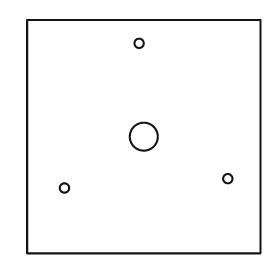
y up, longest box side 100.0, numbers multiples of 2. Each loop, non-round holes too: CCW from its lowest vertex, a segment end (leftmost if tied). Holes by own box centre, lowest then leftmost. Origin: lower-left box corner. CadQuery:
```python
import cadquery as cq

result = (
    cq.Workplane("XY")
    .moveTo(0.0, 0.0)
    .lineTo(100.0, 0.0)
    .lineTo(100.0, 100.0)
    .lineTo(0.0, 100.0)
    .close()
    .moveTo(16.0, 28.0)
    .circle(2.0)
    .moveTo(86.0, 32.0)
    .circle(2.0)
    .moveTo(50.0, 50.0)
    .circle(6.0)
    .moveTo(48.0, 90.0)
    .circle(2.0)
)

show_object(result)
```